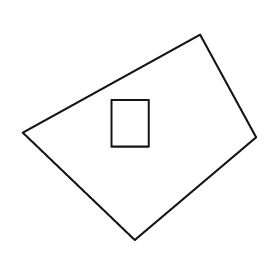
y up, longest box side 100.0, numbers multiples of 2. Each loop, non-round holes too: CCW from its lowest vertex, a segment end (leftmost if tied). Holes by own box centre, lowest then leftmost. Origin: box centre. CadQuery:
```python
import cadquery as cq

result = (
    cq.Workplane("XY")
    .moveTo(-2.0, -44.0)
    .lineTo(50.0, 0.0)
    .lineTo(26.0, 44.0)
    .lineTo(-50.0, 2.0)
    .close()
    .moveTo(-12.0, -4.0)
    .lineTo(4.0, -4.0)
    .lineTo(4.0, 16.0)
    .lineTo(-12.0, 16.0)
    .close()
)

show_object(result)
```